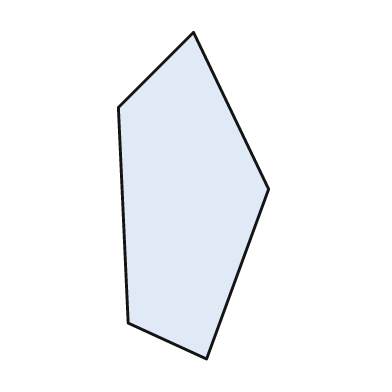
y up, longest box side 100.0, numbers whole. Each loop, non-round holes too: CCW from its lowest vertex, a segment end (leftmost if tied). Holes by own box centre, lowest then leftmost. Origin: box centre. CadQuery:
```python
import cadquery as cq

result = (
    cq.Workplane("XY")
    .moveTo(4.0, -50.0)
    .lineTo(23.0, 2.0)
    .lineTo(0.0, 50.0)
    .lineTo(-23.0, 27.0)
    .lineTo(-20.0, -39.0)
    .close()
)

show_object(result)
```